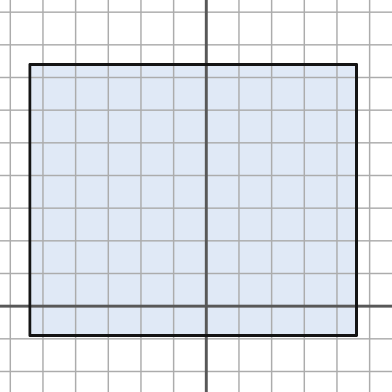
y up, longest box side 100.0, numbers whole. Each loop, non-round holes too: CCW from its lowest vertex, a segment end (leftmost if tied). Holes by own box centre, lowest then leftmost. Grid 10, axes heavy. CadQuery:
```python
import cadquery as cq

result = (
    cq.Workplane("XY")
    .moveTo(-54.0, -9.0)
    .lineTo(46.0, -9.0)
    .lineTo(46.0, 74.0)
    .lineTo(-54.0, 74.0)
    .close()
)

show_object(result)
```